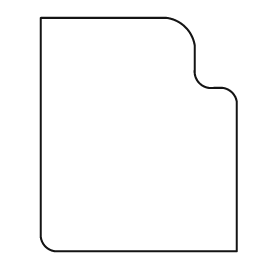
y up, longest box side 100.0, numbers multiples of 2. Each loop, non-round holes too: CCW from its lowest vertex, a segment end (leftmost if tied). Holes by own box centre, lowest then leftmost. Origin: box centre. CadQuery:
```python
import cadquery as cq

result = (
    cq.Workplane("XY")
    .moveTo(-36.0, -50.0)
    .lineTo(42.0, -50.0)
    .lineTo(42.0, 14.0)
    .threePointArc((40.0, 18.0), (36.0, 20.0))
    .lineTo(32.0, 20.0)
    .threePointArc((26.0, 22.0), (24.0, 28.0))
    .lineTo(24.0, 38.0)
    .threePointArc((20.0, 46.0), (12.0, 50.0))
    .lineTo(-42.0, 50.0)
    .lineTo(-42.0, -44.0)
    .threePointArc((-40.0, -48.0), (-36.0, -50.0))
    .close()
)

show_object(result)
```